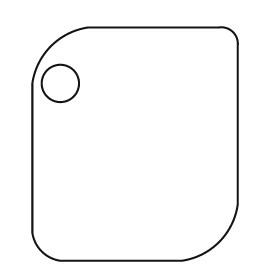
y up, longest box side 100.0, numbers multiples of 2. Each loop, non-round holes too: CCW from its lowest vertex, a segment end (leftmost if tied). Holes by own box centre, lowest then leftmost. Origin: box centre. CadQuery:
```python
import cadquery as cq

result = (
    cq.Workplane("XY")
    .moveTo(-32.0, -50.0)
    .lineTo(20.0, -50.0)
    .threePointArc((36.0, -42.0), (44.0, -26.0))
    .lineTo(44.0, 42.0)
    .threePointArc((42.0, 48.0), (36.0, 50.0))
    .lineTo(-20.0, 50.0)
    .threePointArc((-36.0, 42.0), (-44.0, 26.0))
    .lineTo(-44.0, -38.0)
    .threePointArc((-40.0, -46.0), (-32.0, -50.0))
    .close()
    .moveTo(-32.0, 26.0)
    .circle(8.0)
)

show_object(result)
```